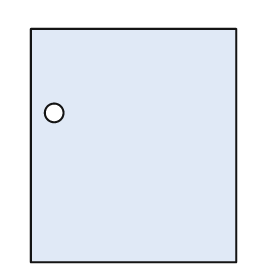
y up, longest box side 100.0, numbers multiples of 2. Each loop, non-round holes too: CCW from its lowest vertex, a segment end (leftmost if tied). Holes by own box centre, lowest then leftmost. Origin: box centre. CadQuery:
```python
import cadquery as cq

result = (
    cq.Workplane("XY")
    .moveTo(-44.0, -50.0)
    .lineTo(44.0, -50.0)
    .lineTo(44.0, 50.0)
    .lineTo(-44.0, 50.0)
    .close()
    .moveTo(-34.0, 14.0)
    .circle(4.0)
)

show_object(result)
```